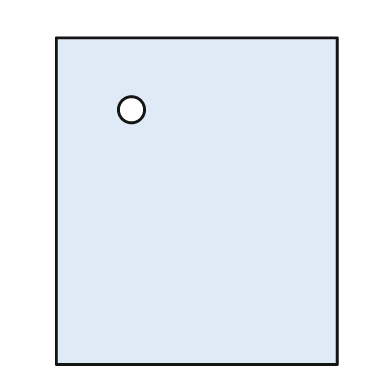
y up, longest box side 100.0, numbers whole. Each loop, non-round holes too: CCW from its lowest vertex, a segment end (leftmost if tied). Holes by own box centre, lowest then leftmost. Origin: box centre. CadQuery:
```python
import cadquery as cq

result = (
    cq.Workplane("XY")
    .moveTo(-43.0, -50.0)
    .lineTo(43.0, -50.0)
    .lineTo(43.0, 50.0)
    .lineTo(-43.0, 50.0)
    .close()
    .moveTo(-20.0, 28.0)
    .circle(4.0)
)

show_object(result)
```